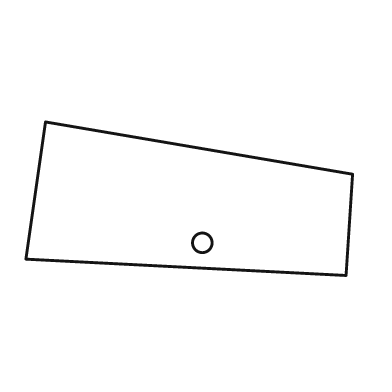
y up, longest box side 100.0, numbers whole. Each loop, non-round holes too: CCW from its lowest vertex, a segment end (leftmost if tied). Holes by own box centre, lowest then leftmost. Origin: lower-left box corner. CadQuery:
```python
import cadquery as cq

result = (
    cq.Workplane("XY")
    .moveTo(98.0, 0.0)
    .lineTo(100.0, 31.0)
    .lineTo(6.0, 47.0)
    .lineTo(0.0, 5.0)
    .close()
    .moveTo(54.0, 10.0)
    .circle(3.0)
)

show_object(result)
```